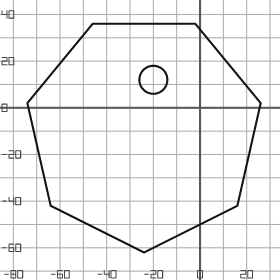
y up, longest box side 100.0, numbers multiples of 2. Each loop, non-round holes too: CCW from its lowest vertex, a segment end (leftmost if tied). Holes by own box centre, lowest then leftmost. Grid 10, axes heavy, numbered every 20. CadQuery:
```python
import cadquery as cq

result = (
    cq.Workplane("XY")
    .moveTo(-24.0, -62.0)
    .lineTo(16.0, -42.0)
    .lineTo(26.0, 2.0)
    .lineTo(-2.0, 36.0)
    .lineTo(-46.0, 36.0)
    .lineTo(-74.0, 2.0)
    .lineTo(-64.0, -42.0)
    .close()
    .moveTo(-20.0, 12.0)
    .circle(6.0)
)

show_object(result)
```